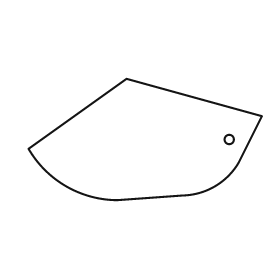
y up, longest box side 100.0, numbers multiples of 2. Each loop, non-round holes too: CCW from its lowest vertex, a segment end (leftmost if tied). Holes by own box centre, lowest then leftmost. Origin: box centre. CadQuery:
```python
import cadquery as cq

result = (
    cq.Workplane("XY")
    .moveTo(-12.0, -26.0)
    .lineTo(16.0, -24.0)
    .threePointArc((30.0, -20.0), (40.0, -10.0))
    .lineTo(50.0, 10.0)
    .lineTo(-8.0, 26.0)
    .lineTo(-50.0, -4.0)
    .threePointArc((-34.0, -20.0), (-12.0, -26.0))
    .close()
    .moveTo(36.0, 0.0)
    .circle(2.0)
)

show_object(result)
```